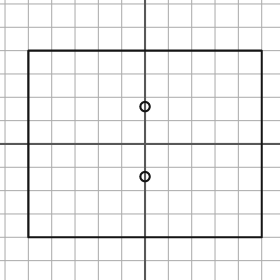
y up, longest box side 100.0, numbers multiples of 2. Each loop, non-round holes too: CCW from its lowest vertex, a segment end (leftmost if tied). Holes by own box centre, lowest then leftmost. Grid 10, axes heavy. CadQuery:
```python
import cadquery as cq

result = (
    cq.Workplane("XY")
    .moveTo(-50.0, -40.0)
    .lineTo(50.0, -40.0)
    .lineTo(50.0, 40.0)
    .lineTo(-50.0, 40.0)
    .close()
    .moveTo(0.0, -14.0)
    .circle(2.0)
    .moveTo(0.0, 16.0)
    .circle(2.0)
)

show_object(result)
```